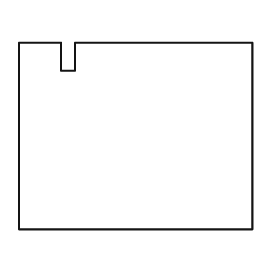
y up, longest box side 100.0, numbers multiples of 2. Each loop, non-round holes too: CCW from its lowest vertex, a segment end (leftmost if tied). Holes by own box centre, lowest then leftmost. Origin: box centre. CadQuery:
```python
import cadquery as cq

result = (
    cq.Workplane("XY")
    .moveTo(-50.0, -40.0)
    .lineTo(50.0, -40.0)
    .lineTo(50.0, 40.0)
    .lineTo(-26.0, 40.0)
    .lineTo(-26.0, 28.0)
    .lineTo(-32.0, 28.0)
    .lineTo(-32.0, 40.0)
    .lineTo(-50.0, 40.0)
    .close()
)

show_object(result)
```